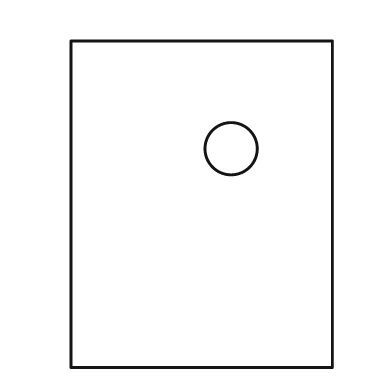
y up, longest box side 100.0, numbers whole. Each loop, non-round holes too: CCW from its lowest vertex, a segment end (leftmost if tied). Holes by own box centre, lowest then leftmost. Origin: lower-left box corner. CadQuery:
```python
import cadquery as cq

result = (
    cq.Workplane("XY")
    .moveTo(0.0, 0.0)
    .lineTo(80.0, 0.0)
    .lineTo(80.0, 100.0)
    .lineTo(0.0, 100.0)
    .close()
    .moveTo(49.0, 67.0)
    .circle(8.0)
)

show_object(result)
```